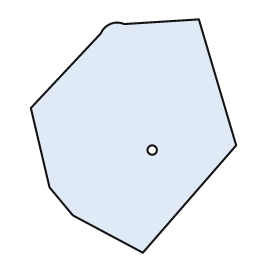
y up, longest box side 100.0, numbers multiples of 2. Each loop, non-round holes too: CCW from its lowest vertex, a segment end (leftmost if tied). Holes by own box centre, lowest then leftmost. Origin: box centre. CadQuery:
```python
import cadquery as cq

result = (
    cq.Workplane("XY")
    .moveTo(4.0, -50.0)
    .lineTo(44.0, -4.0)
    .lineTo(28.0, 50.0)
    .lineTo(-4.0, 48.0)
    .threePointArc((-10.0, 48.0), (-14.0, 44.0))
    .lineTo(-44.0, 12.0)
    .lineTo(-36.0, -22.0)
    .lineTo(-26.0, -34.0)
    .close()
    .moveTo(8.0, -6.0)
    .circle(2.0)
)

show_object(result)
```